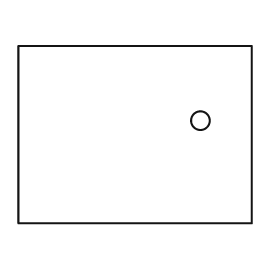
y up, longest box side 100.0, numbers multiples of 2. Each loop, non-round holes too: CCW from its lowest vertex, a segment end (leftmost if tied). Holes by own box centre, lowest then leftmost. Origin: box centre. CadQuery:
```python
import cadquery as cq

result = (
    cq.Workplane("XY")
    .moveTo(-50.0, -38.0)
    .lineTo(50.0, -38.0)
    .lineTo(50.0, 38.0)
    .lineTo(-50.0, 38.0)
    .close()
    .moveTo(28.0, 6.0)
    .circle(4.0)
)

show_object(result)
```